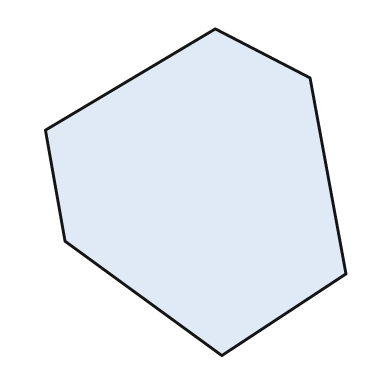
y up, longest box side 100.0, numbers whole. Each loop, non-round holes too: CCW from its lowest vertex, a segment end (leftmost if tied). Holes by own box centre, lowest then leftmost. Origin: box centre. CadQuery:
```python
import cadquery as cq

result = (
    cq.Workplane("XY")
    .moveTo(8.0, -50.0)
    .lineTo(46.0, -25.0)
    .lineTo(35.0, 35.0)
    .lineTo(6.0, 50.0)
    .lineTo(-46.0, 19.0)
    .lineTo(-40.0, -15.0)
    .close()
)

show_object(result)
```